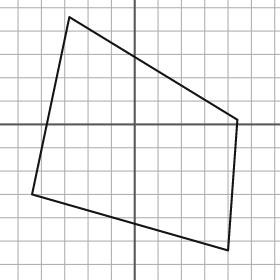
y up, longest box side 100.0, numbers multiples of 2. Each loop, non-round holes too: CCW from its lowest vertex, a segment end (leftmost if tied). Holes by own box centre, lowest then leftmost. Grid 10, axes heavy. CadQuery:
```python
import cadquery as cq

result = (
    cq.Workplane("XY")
    .moveTo(40.0, -54.0)
    .lineTo(44.0, 2.0)
    .lineTo(-28.0, 46.0)
    .lineTo(-44.0, -30.0)
    .close()
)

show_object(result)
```